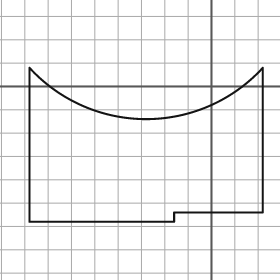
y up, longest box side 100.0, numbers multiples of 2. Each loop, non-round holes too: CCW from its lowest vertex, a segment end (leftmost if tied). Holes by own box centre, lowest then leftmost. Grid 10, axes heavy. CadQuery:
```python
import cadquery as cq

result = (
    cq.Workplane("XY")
    .moveTo(-78.0, -58.0)
    .lineTo(-16.0, -58.0)
    .lineTo(-16.0, -54.0)
    .lineTo(22.0, -54.0)
    .lineTo(22.0, 8.0)
    .threePointArc((-28.0, -14.0), (-78.0, 8.0))
    .close()
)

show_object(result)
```